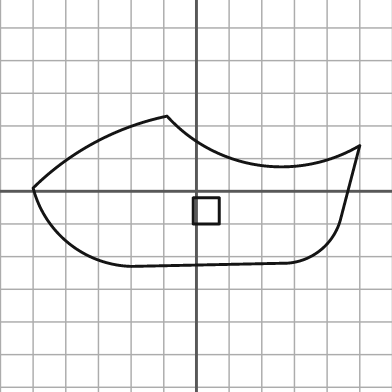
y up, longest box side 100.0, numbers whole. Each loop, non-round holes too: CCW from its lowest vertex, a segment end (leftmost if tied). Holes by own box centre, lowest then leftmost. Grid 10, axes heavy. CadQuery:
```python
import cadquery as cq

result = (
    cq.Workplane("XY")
    .moveTo(-20.0, -23.0)
    .lineTo(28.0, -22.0)
    .threePointArc((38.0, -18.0), (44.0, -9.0))
    .lineTo(50.0, 14.0)
    .threePointArc((19.0, 8.0), (-9.0, 23.0))
    .threePointArc((-31.0, 15.0), (-50.0, 1.0))
    .threePointArc((-39.0, -16.0), (-20.0, -23.0))
    .close()
    .moveTo(-1.0, -10.0)
    .lineTo(7.0, -10.0)
    .lineTo(7.0, -2.0)
    .lineTo(-1.0, -2.0)
    .close()
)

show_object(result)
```